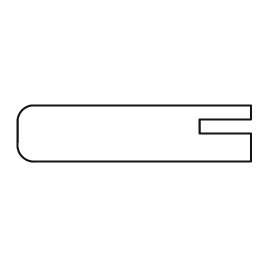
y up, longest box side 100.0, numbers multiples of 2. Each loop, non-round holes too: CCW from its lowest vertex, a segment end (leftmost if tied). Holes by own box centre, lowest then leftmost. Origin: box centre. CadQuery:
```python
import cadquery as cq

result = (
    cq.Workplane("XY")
    .moveTo(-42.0, -12.0)
    .lineTo(50.0, -12.0)
    .lineTo(50.0, 0.0)
    .lineTo(28.0, 0.0)
    .lineTo(28.0, 6.0)
    .lineTo(50.0, 6.0)
    .lineTo(50.0, 12.0)
    .lineTo(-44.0, 12.0)
    .threePointArc((-48.0, 10.0), (-50.0, 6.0))
    .lineTo(-50.0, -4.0)
    .threePointArc((-48.0, -10.0), (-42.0, -12.0))
    .close()
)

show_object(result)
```